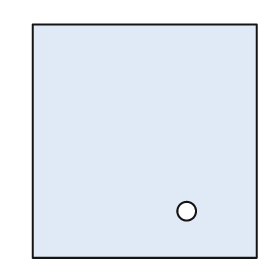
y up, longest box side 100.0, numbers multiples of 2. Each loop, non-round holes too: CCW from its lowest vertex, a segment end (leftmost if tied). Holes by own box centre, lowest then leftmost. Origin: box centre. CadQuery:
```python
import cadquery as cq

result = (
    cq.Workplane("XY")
    .moveTo(-48.0, -50.0)
    .lineTo(48.0, -50.0)
    .lineTo(48.0, 50.0)
    .lineTo(-48.0, 50.0)
    .close()
    .moveTo(18.0, -30.0)
    .circle(4.0)
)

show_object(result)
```